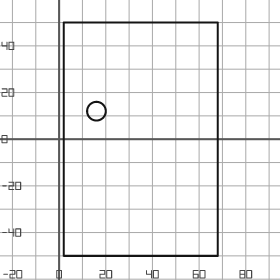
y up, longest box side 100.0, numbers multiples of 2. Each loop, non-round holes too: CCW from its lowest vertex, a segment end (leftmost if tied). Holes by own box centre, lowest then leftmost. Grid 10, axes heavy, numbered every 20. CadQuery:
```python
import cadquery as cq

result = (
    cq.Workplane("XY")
    .moveTo(2.0, -50.0)
    .lineTo(68.0, -50.0)
    .lineTo(68.0, 50.0)
    .lineTo(2.0, 50.0)
    .close()
    .moveTo(16.0, 12.0)
    .circle(4.0)
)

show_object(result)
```